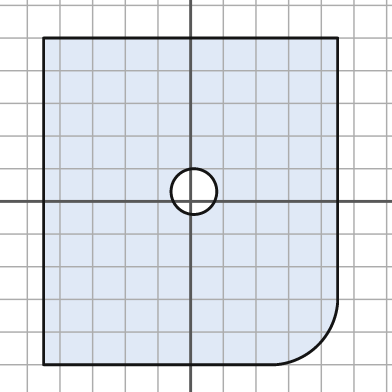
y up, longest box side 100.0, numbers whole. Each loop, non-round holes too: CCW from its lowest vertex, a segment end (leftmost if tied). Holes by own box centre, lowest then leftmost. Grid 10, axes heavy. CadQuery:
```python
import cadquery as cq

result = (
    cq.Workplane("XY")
    .moveTo(-45.0, -50.0)
    .lineTo(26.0, -50.0)
    .threePointArc((39.0, -44.0), (45.0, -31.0))
    .lineTo(45.0, 50.0)
    .lineTo(-45.0, 50.0)
    .close()
    .moveTo(1.0, 3.0)
    .circle(7.0)
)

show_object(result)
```